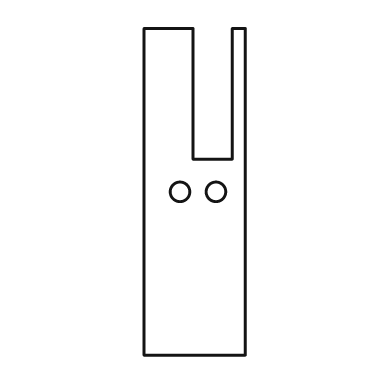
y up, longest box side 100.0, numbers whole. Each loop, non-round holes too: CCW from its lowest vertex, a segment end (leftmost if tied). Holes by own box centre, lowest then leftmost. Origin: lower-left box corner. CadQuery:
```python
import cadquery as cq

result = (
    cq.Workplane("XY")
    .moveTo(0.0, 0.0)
    .lineTo(31.0, 0.0)
    .lineTo(31.0, 100.0)
    .lineTo(27.0, 100.0)
    .lineTo(27.0, 60.0)
    .lineTo(15.0, 60.0)
    .lineTo(15.0, 100.0)
    .lineTo(0.0, 100.0)
    .close()
    .moveTo(11.0, 50.0)
    .circle(3.0)
    .moveTo(22.0, 50.0)
    .circle(3.0)
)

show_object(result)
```